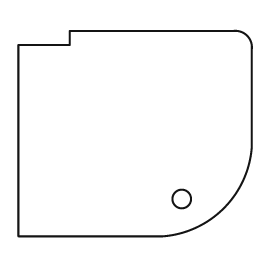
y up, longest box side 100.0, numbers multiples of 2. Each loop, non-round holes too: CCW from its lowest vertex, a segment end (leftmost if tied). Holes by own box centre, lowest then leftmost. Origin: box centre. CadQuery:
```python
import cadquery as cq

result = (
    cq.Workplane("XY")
    .moveTo(-50.0, -44.0)
    .lineTo(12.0, -44.0)
    .threePointArc((38.0, -32.0), (50.0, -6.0))
    .lineTo(50.0, 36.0)
    .threePointArc((48.0, 42.0), (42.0, 44.0))
    .lineTo(-28.0, 44.0)
    .lineTo(-28.0, 38.0)
    .lineTo(-50.0, 38.0)
    .close()
    .moveTo(20.0, -28.0)
    .circle(4.0)
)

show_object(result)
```